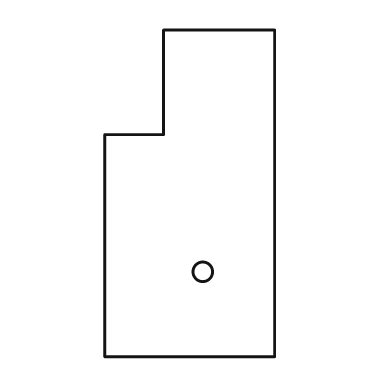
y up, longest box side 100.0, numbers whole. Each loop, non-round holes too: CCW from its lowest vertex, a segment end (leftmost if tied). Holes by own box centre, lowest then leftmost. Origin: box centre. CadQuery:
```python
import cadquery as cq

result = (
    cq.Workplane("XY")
    .moveTo(-26.0, -50.0)
    .lineTo(26.0, -50.0)
    .lineTo(26.0, 50.0)
    .lineTo(-8.0, 50.0)
    .lineTo(-8.0, 18.0)
    .lineTo(-26.0, 18.0)
    .close()
    .moveTo(4.0, -24.0)
    .circle(3.0)
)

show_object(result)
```